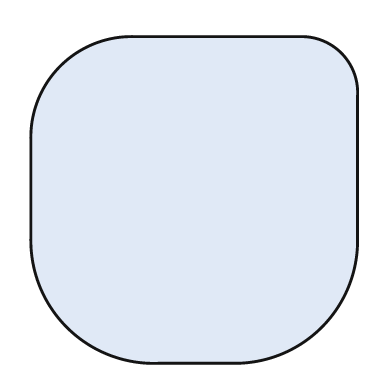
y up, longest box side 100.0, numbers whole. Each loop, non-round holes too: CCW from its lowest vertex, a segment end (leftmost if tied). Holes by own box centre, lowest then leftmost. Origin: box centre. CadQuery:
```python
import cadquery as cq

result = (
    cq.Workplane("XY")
    .moveTo(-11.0, -50.0)
    .lineTo(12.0, -50.0)
    .threePointArc((39.0, -39.0), (50.0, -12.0))
    .lineTo(50.0, 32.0)
    .threePointArc((45.0, 45.0), (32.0, 50.0))
    .lineTo(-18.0, 50.0)
    .threePointArc((-41.0, 41.0), (-50.0, 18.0))
    .lineTo(-50.0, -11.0)
    .threePointArc((-39.0, -39.0), (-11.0, -50.0))
    .close()
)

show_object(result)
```